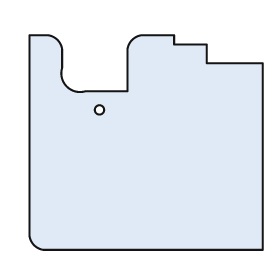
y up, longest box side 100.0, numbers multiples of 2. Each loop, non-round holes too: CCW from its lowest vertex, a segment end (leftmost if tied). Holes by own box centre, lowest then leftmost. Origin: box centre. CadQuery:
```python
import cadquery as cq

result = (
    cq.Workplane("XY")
    .moveTo(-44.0, -46.0)
    .lineTo(50.0, -46.0)
    .lineTo(50.0, 34.0)
    .lineTo(26.0, 34.0)
    .lineTo(26.0, 42.0)
    .lineTo(12.0, 42.0)
    .lineTo(12.0, 46.0)
    .lineTo(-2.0, 46.0)
    .threePointArc((-6.0, 44.0), (-8.0, 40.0))
    .lineTo(-8.0, 22.0)
    .lineTo(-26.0, 22.0)
    .threePointArc((-34.0, 24.0), (-36.0, 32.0))
    .lineTo(-36.0, 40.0)
    .threePointArc((-38.0, 44.0), (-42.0, 46.0))
    .lineTo(-50.0, 46.0)
    .lineTo(-50.0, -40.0)
    .threePointArc((-48.0, -44.0), (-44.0, -46.0))
    .close()
    .moveTo(-20.0, 14.0)
    .circle(2.0)
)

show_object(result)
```